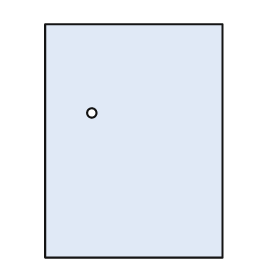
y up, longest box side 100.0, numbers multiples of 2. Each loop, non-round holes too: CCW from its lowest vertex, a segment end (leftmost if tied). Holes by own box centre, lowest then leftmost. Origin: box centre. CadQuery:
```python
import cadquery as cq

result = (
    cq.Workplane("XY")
    .moveTo(-38.0, -50.0)
    .lineTo(38.0, -50.0)
    .lineTo(38.0, 50.0)
    .lineTo(-38.0, 50.0)
    .close()
    .moveTo(-18.0, 12.0)
    .circle(2.0)
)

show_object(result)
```